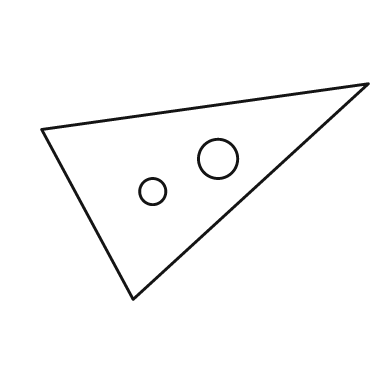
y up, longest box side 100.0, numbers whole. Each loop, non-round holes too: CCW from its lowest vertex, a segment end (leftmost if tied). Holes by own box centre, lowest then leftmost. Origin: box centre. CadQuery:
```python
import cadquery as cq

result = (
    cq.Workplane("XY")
    .moveTo(-22.0, -33.0)
    .lineTo(50.0, 33.0)
    .lineTo(-50.0, 19.0)
    .close()
    .moveTo(-16.0, 0.0)
    .circle(4.0)
    .moveTo(4.0, 10.0)
    .circle(6.0)
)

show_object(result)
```